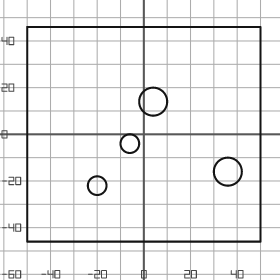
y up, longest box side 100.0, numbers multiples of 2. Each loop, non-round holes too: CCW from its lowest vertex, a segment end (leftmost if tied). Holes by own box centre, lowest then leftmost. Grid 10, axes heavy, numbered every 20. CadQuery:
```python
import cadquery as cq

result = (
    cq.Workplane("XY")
    .moveTo(-50.0, -46.0)
    .lineTo(50.0, -46.0)
    .lineTo(50.0, 46.0)
    .lineTo(-50.0, 46.0)
    .close()
    .moveTo(-20.0, -22.0)
    .circle(4.0)
    .moveTo(36.0, -16.0)
    .circle(6.0)
    .moveTo(-6.0, -4.0)
    .circle(4.0)
    .moveTo(4.0, 14.0)
    .circle(6.0)
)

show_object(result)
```